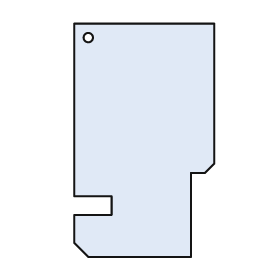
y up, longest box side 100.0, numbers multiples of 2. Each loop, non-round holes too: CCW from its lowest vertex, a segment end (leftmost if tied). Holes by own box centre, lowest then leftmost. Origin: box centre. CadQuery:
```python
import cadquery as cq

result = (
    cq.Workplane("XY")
    .moveTo(-24.0, -50.0)
    .lineTo(20.0, -50.0)
    .lineTo(20.0, -14.0)
    .lineTo(26.0, -14.0)
    .lineTo(30.0, -10.0)
    .lineTo(30.0, 50.0)
    .lineTo(-30.0, 50.0)
    .lineTo(-30.0, -24.0)
    .lineTo(-14.0, -24.0)
    .lineTo(-14.0, -32.0)
    .lineTo(-30.0, -32.0)
    .lineTo(-30.0, -44.0)
    .close()
    .moveTo(-24.0, 44.0)
    .circle(2.0)
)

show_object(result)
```